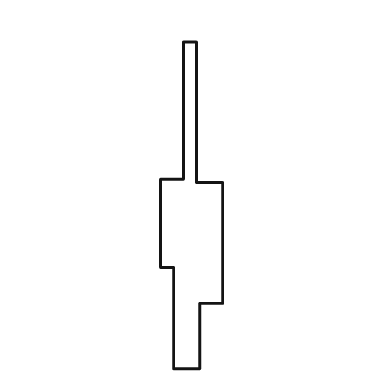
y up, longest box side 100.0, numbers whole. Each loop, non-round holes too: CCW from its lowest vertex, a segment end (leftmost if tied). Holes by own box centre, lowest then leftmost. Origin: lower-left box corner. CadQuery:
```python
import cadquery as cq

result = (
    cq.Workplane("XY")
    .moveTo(4.0, 0.0)
    .lineTo(12.0, 0.0)
    .lineTo(12.0, 20.0)
    .lineTo(19.0, 20.0)
    .lineTo(19.0, 57.0)
    .lineTo(11.0, 57.0)
    .lineTo(11.0, 100.0)
    .lineTo(7.0, 100.0)
    .lineTo(7.0, 58.0)
    .lineTo(0.0, 58.0)
    .lineTo(0.0, 31.0)
    .lineTo(4.0, 31.0)
    .close()
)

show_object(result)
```